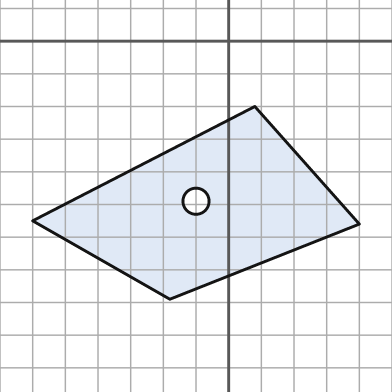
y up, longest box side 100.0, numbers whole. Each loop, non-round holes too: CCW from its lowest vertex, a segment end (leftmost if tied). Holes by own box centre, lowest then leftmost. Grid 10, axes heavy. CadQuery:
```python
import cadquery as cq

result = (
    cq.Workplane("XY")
    .moveTo(-18.0, -79.0)
    .lineTo(40.0, -56.0)
    .lineTo(8.0, -20.0)
    .lineTo(-60.0, -55.0)
    .close()
    .moveTo(-10.0, -49.0)
    .circle(4.0)
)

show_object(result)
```